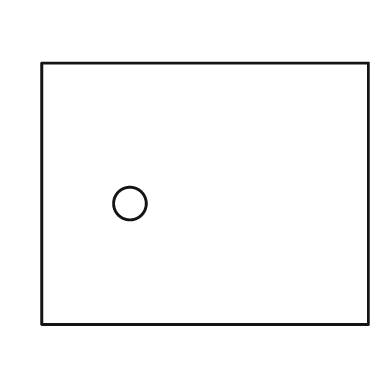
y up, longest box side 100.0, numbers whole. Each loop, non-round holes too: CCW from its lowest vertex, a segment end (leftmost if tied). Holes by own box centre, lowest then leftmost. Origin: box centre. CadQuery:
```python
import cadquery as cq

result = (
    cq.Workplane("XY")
    .moveTo(-50.0, -40.0)
    .lineTo(50.0, -40.0)
    .lineTo(50.0, 40.0)
    .lineTo(-50.0, 40.0)
    .close()
    .moveTo(-23.0, -3.0)
    .circle(5.0)
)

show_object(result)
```